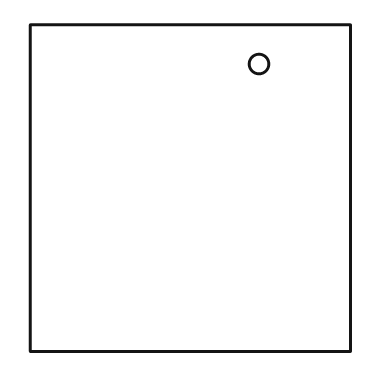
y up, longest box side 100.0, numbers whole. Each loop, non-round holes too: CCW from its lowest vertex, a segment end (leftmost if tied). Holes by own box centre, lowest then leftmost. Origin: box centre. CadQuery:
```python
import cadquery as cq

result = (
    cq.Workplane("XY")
    .moveTo(-49.0, -50.0)
    .lineTo(49.0, -50.0)
    .lineTo(49.0, 50.0)
    .lineTo(-49.0, 50.0)
    .close()
    .moveTo(21.0, 38.0)
    .circle(3.0)
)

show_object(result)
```